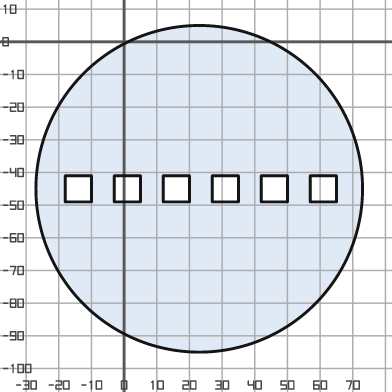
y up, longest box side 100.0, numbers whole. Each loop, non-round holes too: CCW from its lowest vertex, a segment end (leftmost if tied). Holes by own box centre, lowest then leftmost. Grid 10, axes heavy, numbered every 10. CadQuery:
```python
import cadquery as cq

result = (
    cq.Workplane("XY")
    .moveTo(23.0, -45.0)
    .circle(50.0)
    .moveTo(-18.0, -49.0)
    .lineTo(-10.0, -49.0)
    .lineTo(-10.0, -41.0)
    .lineTo(-18.0, -41.0)
    .close()
    .moveTo(-3.0, -49.0)
    .lineTo(5.0, -49.0)
    .lineTo(5.0, -41.0)
    .lineTo(-3.0, -41.0)
    .close()
    .moveTo(12.0, -49.0)
    .lineTo(20.0, -49.0)
    .lineTo(20.0, -41.0)
    .lineTo(12.0, -41.0)
    .close()
    .moveTo(27.0, -49.0)
    .lineTo(35.0, -49.0)
    .lineTo(35.0, -41.0)
    .lineTo(27.0, -41.0)
    .close()
    .moveTo(42.0, -49.0)
    .lineTo(50.0, -49.0)
    .lineTo(50.0, -41.0)
    .lineTo(42.0, -41.0)
    .close()
    .moveTo(57.0, -49.0)
    .lineTo(65.0, -49.0)
    .lineTo(65.0, -41.0)
    .lineTo(57.0, -41.0)
    .close()
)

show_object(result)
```